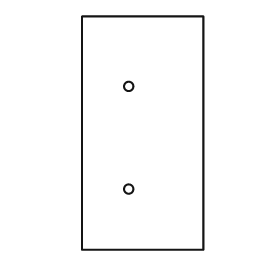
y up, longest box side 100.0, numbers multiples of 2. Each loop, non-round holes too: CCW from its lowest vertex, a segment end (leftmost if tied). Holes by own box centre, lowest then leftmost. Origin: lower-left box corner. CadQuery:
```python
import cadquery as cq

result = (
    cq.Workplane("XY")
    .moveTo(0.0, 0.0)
    .lineTo(52.0, 0.0)
    .lineTo(52.0, 100.0)
    .lineTo(0.0, 100.0)
    .close()
    .moveTo(20.0, 26.0)
    .circle(2.0)
    .moveTo(20.0, 70.0)
    .circle(2.0)
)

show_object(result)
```